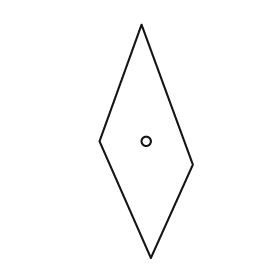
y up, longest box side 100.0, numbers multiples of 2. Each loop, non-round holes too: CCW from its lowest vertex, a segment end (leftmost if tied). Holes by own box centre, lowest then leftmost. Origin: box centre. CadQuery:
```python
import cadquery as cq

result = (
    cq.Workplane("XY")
    .moveTo(2.0, -50.0)
    .lineTo(20.0, -10.0)
    .lineTo(-2.0, 50.0)
    .lineTo(-20.0, 0.0)
    .close()
    .moveTo(0.0, 0.0)
    .circle(2.0)
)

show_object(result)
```